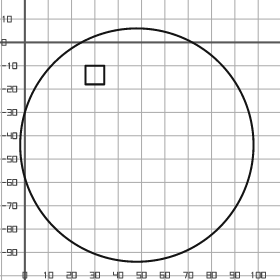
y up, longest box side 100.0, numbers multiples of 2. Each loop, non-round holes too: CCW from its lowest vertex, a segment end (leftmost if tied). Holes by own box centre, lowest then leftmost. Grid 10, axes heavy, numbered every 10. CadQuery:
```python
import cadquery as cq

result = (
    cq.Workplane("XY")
    .moveTo(48.0, -44.0)
    .circle(50.0)
    .moveTo(26.0, -18.0)
    .lineTo(34.0, -18.0)
    .lineTo(34.0, -10.0)
    .lineTo(26.0, -10.0)
    .close()
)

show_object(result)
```